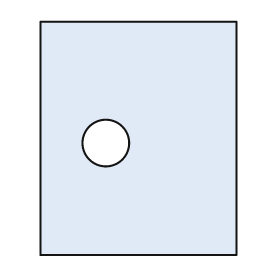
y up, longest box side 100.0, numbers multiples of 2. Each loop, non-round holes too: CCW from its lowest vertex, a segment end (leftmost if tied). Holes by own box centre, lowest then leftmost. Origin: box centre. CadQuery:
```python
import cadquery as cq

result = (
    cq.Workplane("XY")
    .moveTo(-42.0, -50.0)
    .lineTo(42.0, -50.0)
    .lineTo(42.0, 50.0)
    .lineTo(-42.0, 50.0)
    .close()
    .moveTo(-14.0, -2.0)
    .circle(10.0)
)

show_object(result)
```